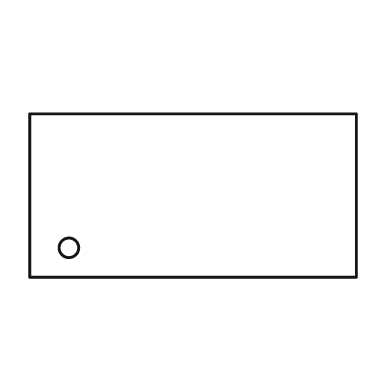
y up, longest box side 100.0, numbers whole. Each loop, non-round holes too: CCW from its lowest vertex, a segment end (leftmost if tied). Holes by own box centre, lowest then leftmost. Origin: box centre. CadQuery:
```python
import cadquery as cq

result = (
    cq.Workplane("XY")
    .moveTo(-50.0, -25.0)
    .lineTo(50.0, -25.0)
    .lineTo(50.0, 25.0)
    .lineTo(-50.0, 25.0)
    .close()
    .moveTo(-38.0, -16.0)
    .circle(3.0)
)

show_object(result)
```